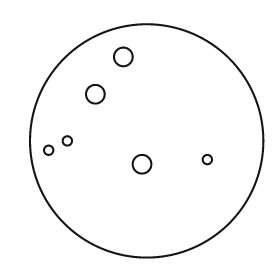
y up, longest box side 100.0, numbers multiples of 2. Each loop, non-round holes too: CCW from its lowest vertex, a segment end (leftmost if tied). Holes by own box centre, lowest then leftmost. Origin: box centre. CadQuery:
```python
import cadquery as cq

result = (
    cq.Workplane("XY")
    .moveTo(0.0, 0.0)
    .circle(50.0)
    .moveTo(-2.0, -10.0)
    .circle(4.0)
    .moveTo(26.0, -8.0)
    .circle(2.0)
    .moveTo(-42.0, -4.0)
    .circle(2.0)
    .moveTo(-34.0, 0.0)
    .circle(2.0)
    .moveTo(-22.0, 20.0)
    .circle(4.0)
    .moveTo(-10.0, 36.0)
    .circle(4.0)
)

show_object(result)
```